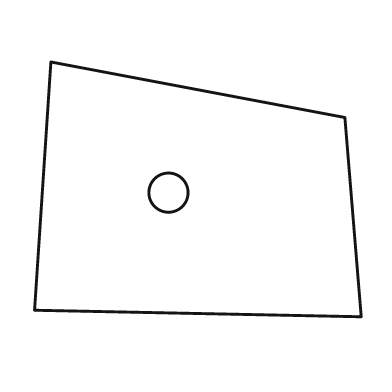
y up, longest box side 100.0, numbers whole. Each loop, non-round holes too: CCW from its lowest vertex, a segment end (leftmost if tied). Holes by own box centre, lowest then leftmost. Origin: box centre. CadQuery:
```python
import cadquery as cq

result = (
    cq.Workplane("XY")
    .moveTo(50.0, -39.0)
    .lineTo(45.0, 22.0)
    .lineTo(-45.0, 39.0)
    .lineTo(-50.0, -37.0)
    .close()
    .moveTo(-9.0, -1.0)
    .circle(6.0)
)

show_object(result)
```